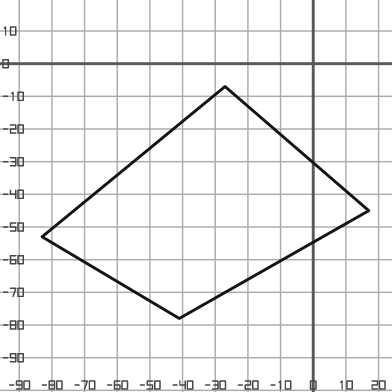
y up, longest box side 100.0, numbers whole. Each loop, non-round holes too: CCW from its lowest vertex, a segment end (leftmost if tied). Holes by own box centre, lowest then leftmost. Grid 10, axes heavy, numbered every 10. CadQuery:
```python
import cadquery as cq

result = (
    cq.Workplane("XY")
    .moveTo(-41.0, -78.0)
    .lineTo(17.0, -45.0)
    .lineTo(-27.0, -7.0)
    .lineTo(-83.0, -53.0)
    .close()
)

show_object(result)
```